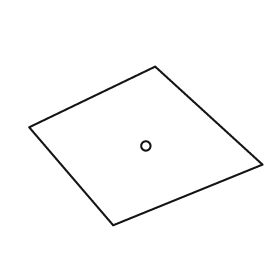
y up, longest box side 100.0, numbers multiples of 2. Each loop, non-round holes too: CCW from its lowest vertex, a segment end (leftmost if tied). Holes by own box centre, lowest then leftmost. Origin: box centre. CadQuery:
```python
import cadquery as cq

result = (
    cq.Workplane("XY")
    .moveTo(-14.0, -34.0)
    .lineTo(50.0, -8.0)
    .lineTo(4.0, 34.0)
    .lineTo(-50.0, 8.0)
    .close()
    .moveTo(0.0, 0.0)
    .circle(2.0)
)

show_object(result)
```